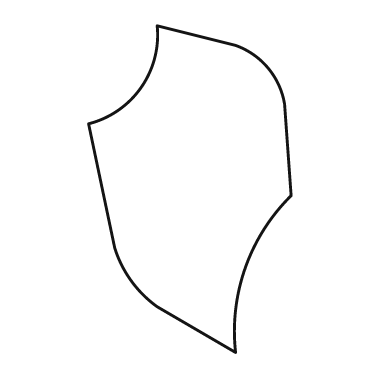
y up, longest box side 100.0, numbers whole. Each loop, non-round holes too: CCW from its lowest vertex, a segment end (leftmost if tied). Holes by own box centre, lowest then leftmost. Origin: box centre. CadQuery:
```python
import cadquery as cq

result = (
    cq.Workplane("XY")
    .moveTo(14.0, -50.0)
    .threePointArc((17.0, -24.0), (31.0, -2.0))
    .lineTo(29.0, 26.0)
    .threePointArc((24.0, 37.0), (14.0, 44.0))
    .lineTo(-10.0, 50.0)
    .threePointArc((-15.0, 31.0), (-31.0, 20.0))
    .lineTo(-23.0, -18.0)
    .threePointArc((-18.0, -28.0), (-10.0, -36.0))
    .close()
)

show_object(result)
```